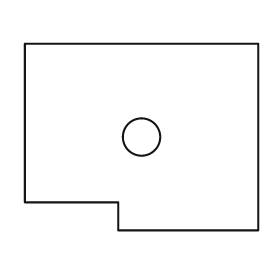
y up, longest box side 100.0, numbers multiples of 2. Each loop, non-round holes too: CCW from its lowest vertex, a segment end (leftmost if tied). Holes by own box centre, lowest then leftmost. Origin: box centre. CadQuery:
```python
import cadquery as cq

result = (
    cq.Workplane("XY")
    .moveTo(-10.0, -40.0)
    .lineTo(50.0, -40.0)
    .lineTo(50.0, 40.0)
    .lineTo(-50.0, 40.0)
    .lineTo(-50.0, -28.0)
    .lineTo(-10.0, -28.0)
    .close()
    .moveTo(0.0, 0.0)
    .circle(8.0)
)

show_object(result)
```